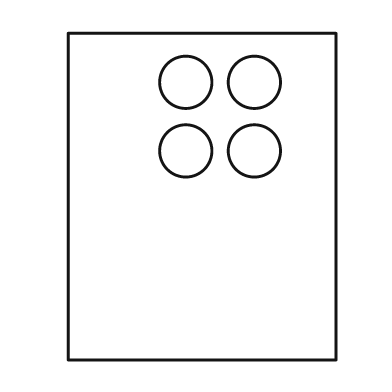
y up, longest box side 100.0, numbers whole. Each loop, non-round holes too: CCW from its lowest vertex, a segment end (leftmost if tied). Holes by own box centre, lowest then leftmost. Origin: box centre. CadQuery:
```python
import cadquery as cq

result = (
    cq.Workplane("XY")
    .moveTo(-41.0, -50.0)
    .lineTo(41.0, -50.0)
    .lineTo(41.0, 50.0)
    .lineTo(-41.0, 50.0)
    .close()
    .moveTo(-5.0, 14.0)
    .circle(8.0)
    .moveTo(16.0, 14.0)
    .circle(8.0)
    .moveTo(-5.0, 35.0)
    .circle(8.0)
    .moveTo(16.0, 35.0)
    .circle(8.0)
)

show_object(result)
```